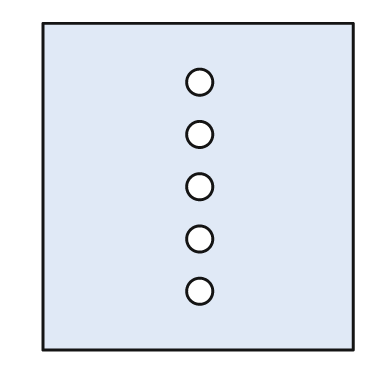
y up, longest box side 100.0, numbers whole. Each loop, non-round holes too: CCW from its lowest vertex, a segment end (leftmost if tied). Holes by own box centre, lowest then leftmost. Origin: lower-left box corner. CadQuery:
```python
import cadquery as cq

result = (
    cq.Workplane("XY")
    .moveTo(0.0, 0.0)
    .lineTo(95.0, 0.0)
    .lineTo(95.0, 100.0)
    .lineTo(0.0, 100.0)
    .close()
    .moveTo(48.0, 18.0)
    .circle(4.0)
    .moveTo(48.0, 34.0)
    .circle(4.0)
    .moveTo(48.0, 50.0)
    .circle(4.0)
    .moveTo(48.0, 66.0)
    .circle(4.0)
    .moveTo(48.0, 82.0)
    .circle(4.0)
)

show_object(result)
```